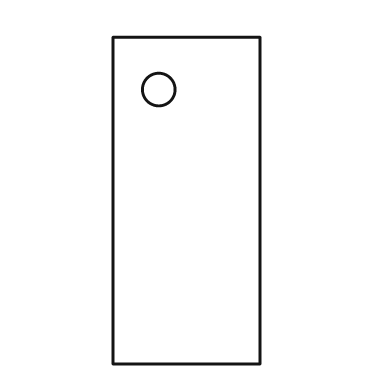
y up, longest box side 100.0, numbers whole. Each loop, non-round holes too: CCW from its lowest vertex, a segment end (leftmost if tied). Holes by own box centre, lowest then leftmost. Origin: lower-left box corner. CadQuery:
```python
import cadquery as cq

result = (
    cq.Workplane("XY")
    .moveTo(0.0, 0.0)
    .lineTo(45.0, 0.0)
    .lineTo(45.0, 100.0)
    .lineTo(0.0, 100.0)
    .close()
    .moveTo(14.0, 84.0)
    .circle(5.0)
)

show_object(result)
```